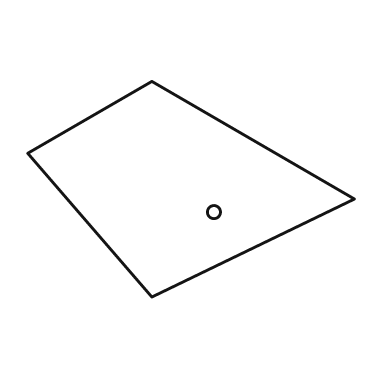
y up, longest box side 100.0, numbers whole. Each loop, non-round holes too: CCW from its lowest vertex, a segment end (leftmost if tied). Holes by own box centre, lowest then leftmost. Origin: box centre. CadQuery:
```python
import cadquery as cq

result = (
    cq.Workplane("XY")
    .moveTo(-12.0, -33.0)
    .lineTo(50.0, -3.0)
    .lineTo(-12.0, 33.0)
    .lineTo(-50.0, 11.0)
    .close()
    .moveTo(7.0, -7.0)
    .circle(2.0)
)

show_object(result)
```